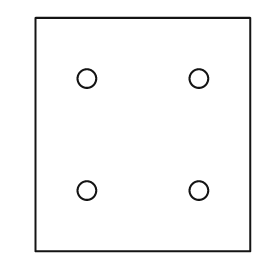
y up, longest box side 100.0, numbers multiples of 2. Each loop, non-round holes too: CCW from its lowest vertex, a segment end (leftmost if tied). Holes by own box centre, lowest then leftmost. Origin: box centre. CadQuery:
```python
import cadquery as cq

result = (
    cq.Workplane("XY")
    .moveTo(-46.0, -50.0)
    .lineTo(46.0, -50.0)
    .lineTo(46.0, 50.0)
    .lineTo(-46.0, 50.0)
    .close()
    .moveTo(-24.0, -24.0)
    .circle(4.0)
    .moveTo(24.0, -24.0)
    .circle(4.0)
    .moveTo(-24.0, 24.0)
    .circle(4.0)
    .moveTo(24.0, 24.0)
    .circle(4.0)
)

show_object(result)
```